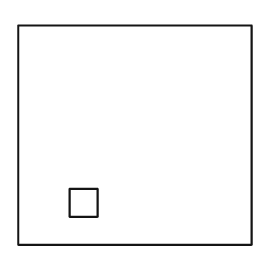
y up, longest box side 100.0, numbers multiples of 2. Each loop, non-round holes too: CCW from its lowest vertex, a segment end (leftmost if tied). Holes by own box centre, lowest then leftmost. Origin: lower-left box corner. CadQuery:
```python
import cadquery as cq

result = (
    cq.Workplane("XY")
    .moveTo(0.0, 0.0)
    .lineTo(100.0, 0.0)
    .lineTo(100.0, 94.0)
    .lineTo(0.0, 94.0)
    .close()
    .moveTo(22.0, 12.0)
    .lineTo(34.0, 12.0)
    .lineTo(34.0, 24.0)
    .lineTo(22.0, 24.0)
    .close()
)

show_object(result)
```